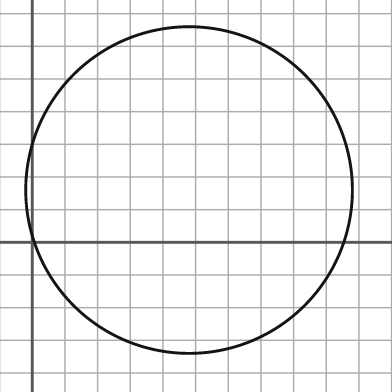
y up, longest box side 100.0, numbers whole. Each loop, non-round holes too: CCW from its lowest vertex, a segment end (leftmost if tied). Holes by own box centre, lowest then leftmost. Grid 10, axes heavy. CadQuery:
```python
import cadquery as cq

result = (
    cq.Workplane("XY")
    .moveTo(48.0, 16.0)
    .circle(50.0)
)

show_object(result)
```